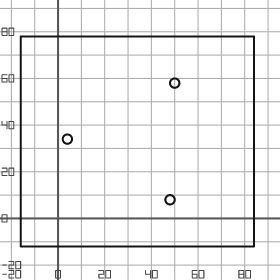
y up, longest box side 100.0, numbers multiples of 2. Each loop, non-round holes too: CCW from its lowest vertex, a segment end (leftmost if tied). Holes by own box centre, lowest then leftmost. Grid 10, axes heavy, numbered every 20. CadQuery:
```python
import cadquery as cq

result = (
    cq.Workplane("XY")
    .moveTo(-16.0, -12.0)
    .lineTo(84.0, -12.0)
    .lineTo(84.0, 78.0)
    .lineTo(-16.0, 78.0)
    .close()
    .moveTo(48.0, 8.0)
    .circle(2.0)
    .moveTo(4.0, 34.0)
    .circle(2.0)
    .moveTo(50.0, 58.0)
    .circle(2.0)
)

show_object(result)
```